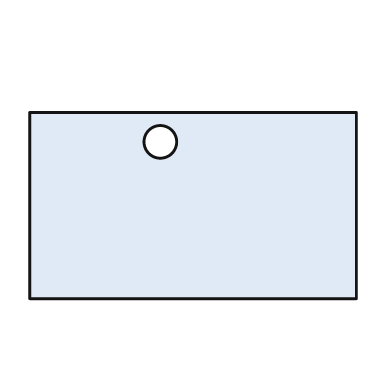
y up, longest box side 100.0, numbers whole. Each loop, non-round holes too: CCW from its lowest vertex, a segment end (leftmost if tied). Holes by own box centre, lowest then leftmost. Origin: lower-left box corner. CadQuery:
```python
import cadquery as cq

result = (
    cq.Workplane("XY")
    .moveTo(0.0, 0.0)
    .lineTo(100.0, 0.0)
    .lineTo(100.0, 57.0)
    .lineTo(0.0, 57.0)
    .close()
    .moveTo(40.0, 48.0)
    .circle(5.0)
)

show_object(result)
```